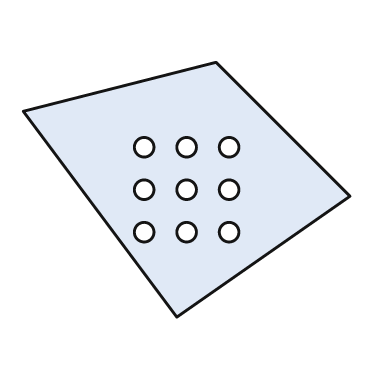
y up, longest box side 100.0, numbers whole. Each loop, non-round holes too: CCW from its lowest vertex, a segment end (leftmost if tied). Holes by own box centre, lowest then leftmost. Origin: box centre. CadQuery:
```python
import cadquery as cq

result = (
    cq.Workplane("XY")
    .moveTo(-3.0, -39.0)
    .lineTo(50.0, -2.0)
    .lineTo(9.0, 39.0)
    .lineTo(-50.0, 24.0)
    .close()
    .moveTo(-13.0, -13.0)
    .circle(3.0)
    .moveTo(0.0, -13.0)
    .circle(3.0)
    .moveTo(13.0, -13.0)
    .circle(3.0)
    .moveTo(-13.0, 0.0)
    .circle(3.0)
    .moveTo(0.0, 0.0)
    .circle(3.0)
    .moveTo(13.0, 0.0)
    .circle(3.0)
    .moveTo(-13.0, 13.0)
    .circle(3.0)
    .moveTo(0.0, 13.0)
    .circle(3.0)
    .moveTo(13.0, 13.0)
    .circle(3.0)
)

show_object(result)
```